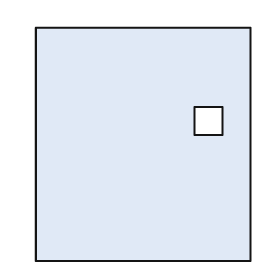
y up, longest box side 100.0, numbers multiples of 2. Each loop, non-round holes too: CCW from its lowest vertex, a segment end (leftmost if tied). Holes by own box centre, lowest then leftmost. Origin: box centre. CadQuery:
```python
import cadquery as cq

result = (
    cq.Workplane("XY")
    .moveTo(-46.0, -50.0)
    .lineTo(46.0, -50.0)
    .lineTo(46.0, 50.0)
    .lineTo(-46.0, 50.0)
    .close()
    .moveTo(22.0, 4.0)
    .lineTo(34.0, 4.0)
    .lineTo(34.0, 16.0)
    .lineTo(22.0, 16.0)
    .close()
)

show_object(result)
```